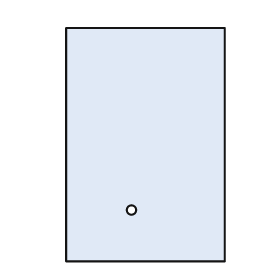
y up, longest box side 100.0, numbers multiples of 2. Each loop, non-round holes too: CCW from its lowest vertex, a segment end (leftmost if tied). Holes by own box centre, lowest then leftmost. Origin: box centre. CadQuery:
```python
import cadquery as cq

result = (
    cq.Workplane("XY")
    .moveTo(-34.0, -50.0)
    .lineTo(34.0, -50.0)
    .lineTo(34.0, 50.0)
    .lineTo(-34.0, 50.0)
    .close()
    .moveTo(-6.0, -28.0)
    .circle(2.0)
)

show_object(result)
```